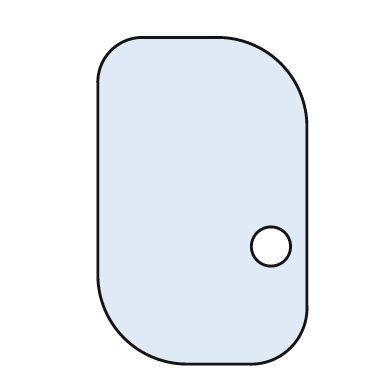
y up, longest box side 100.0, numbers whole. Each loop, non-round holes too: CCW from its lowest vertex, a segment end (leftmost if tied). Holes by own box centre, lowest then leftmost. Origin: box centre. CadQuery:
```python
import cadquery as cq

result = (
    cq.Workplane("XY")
    .moveTo(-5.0, -50.0)
    .lineTo(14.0, -50.0)
    .threePointArc((27.0, -45.0), (32.0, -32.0))
    .lineTo(32.0, 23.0)
    .threePointArc((24.0, 42.0), (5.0, 50.0))
    .lineTo(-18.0, 50.0)
    .threePointArc((-28.0, 46.0), (-32.0, 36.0))
    .lineTo(-32.0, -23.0)
    .threePointArc((-24.0, -42.0), (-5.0, -50.0))
    .close()
    .moveTo(21.0, -14.0)
    .circle(6.0)
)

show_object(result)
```